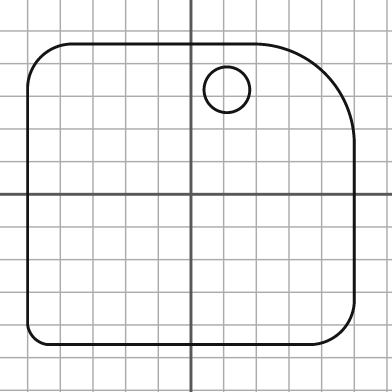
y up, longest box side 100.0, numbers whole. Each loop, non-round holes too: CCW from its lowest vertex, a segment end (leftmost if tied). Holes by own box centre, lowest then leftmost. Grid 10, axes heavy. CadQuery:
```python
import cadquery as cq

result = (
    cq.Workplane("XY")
    .moveTo(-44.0, -46.0)
    .lineTo(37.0, -46.0)
    .threePointArc((46.0, -42.0), (50.0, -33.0))
    .lineTo(50.0, 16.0)
    .threePointArc((41.0, 37.0), (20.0, 46.0))
    .lineTo(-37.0, 46.0)
    .threePointArc((-46.0, 42.0), (-50.0, 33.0))
    .lineTo(-50.0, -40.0)
    .threePointArc((-48.0, -44.0), (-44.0, -46.0))
    .close()
    .moveTo(11.0, 32.0)
    .circle(7.0)
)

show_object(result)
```